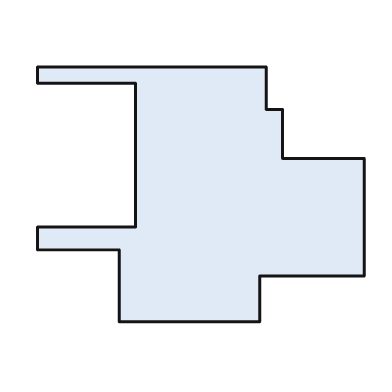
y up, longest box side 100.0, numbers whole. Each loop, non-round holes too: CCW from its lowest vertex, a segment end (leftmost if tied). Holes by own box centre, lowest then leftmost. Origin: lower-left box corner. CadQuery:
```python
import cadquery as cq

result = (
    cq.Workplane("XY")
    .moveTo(25.0, 0.0)
    .lineTo(68.0, 0.0)
    .lineTo(68.0, 14.0)
    .lineTo(100.0, 14.0)
    .lineTo(100.0, 50.0)
    .lineTo(75.0, 50.0)
    .lineTo(75.0, 65.0)
    .lineTo(70.0, 65.0)
    .lineTo(70.0, 78.0)
    .lineTo(0.0, 78.0)
    .lineTo(0.0, 73.0)
    .lineTo(30.0, 73.0)
    .lineTo(30.0, 29.0)
    .lineTo(0.0, 29.0)
    .lineTo(0.0, 22.0)
    .lineTo(25.0, 22.0)
    .close()
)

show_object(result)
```